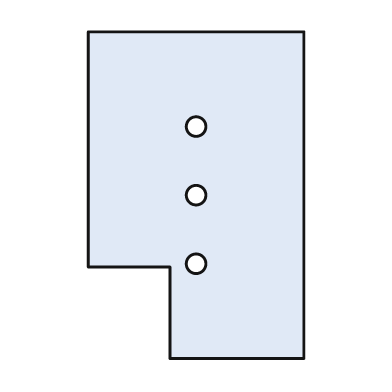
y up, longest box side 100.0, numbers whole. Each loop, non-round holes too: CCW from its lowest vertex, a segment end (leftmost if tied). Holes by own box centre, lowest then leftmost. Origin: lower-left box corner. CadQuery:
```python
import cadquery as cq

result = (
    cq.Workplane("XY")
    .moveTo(25.0, 0.0)
    .lineTo(66.0, 0.0)
    .lineTo(66.0, 100.0)
    .lineTo(0.0, 100.0)
    .lineTo(0.0, 28.0)
    .lineTo(25.0, 28.0)
    .close()
    .moveTo(33.0, 29.0)
    .circle(3.0)
    .moveTo(33.0, 50.0)
    .circle(3.0)
    .moveTo(33.0, 71.0)
    .circle(3.0)
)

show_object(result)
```